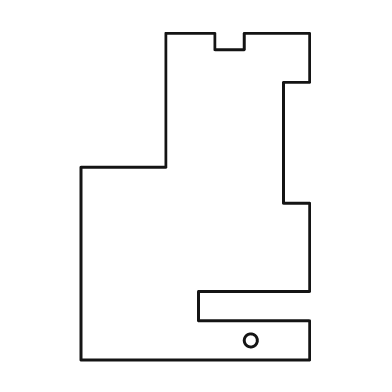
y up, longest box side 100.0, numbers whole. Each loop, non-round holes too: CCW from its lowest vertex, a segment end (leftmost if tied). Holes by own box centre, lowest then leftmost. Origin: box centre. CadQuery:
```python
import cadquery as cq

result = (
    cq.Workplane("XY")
    .moveTo(-35.0, -50.0)
    .lineTo(35.0, -50.0)
    .lineTo(35.0, -38.0)
    .lineTo(1.0, -38.0)
    .lineTo(1.0, -29.0)
    .lineTo(35.0, -29.0)
    .lineTo(35.0, -2.0)
    .lineTo(27.0, -2.0)
    .lineTo(27.0, 35.0)
    .lineTo(35.0, 35.0)
    .lineTo(35.0, 50.0)
    .lineTo(15.0, 50.0)
    .lineTo(15.0, 45.0)
    .lineTo(6.0, 45.0)
    .lineTo(6.0, 50.0)
    .lineTo(-9.0, 50.0)
    .lineTo(-9.0, 9.0)
    .lineTo(-35.0, 9.0)
    .close()
    .moveTo(17.0, -44.0)
    .circle(2.0)
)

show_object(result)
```